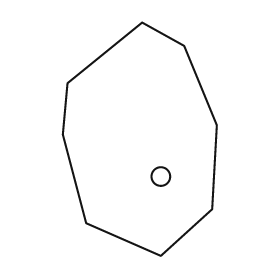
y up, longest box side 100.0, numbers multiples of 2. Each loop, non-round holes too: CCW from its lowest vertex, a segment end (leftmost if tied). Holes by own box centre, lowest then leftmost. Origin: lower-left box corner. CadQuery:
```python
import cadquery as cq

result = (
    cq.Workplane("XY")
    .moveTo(42.0, 0.0)
    .lineTo(64.0, 20.0)
    .lineTo(66.0, 56.0)
    .lineTo(52.0, 90.0)
    .lineTo(34.0, 100.0)
    .lineTo(2.0, 74.0)
    .lineTo(0.0, 52.0)
    .lineTo(10.0, 14.0)
    .close()
    .moveTo(42.0, 34.0)
    .circle(4.0)
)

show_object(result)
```